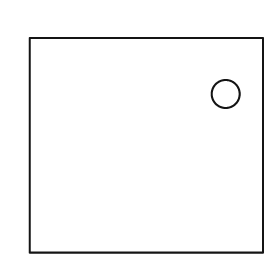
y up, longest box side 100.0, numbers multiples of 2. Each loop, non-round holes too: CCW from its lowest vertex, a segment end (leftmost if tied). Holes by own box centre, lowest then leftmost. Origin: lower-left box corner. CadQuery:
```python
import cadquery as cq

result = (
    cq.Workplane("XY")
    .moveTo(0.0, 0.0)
    .lineTo(100.0, 0.0)
    .lineTo(100.0, 92.0)
    .lineTo(0.0, 92.0)
    .close()
    .moveTo(84.0, 68.0)
    .circle(6.0)
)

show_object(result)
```